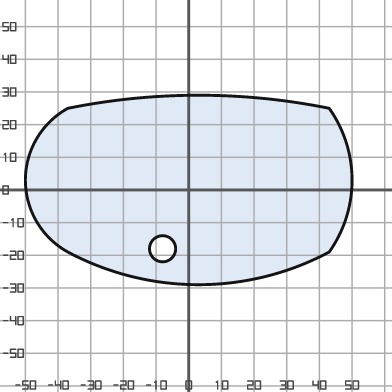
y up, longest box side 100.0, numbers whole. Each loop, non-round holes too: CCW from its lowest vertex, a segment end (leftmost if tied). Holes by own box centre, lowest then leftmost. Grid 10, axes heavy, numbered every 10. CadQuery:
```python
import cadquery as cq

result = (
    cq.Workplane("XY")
    .moveTo(-37.0, -19.0)
    .threePointArc((3.0, -29.0), (43.0, -19.0))
    .threePointArc((50.0, 3.0), (43.0, 25.0))
    .threePointArc((3.0, 29.0), (-37.0, 25.0))
    .threePointArc((-50.0, 3.0), (-37.0, -19.0))
    .close()
    .moveTo(-8.0, -18.0)
    .circle(4.0)
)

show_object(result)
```